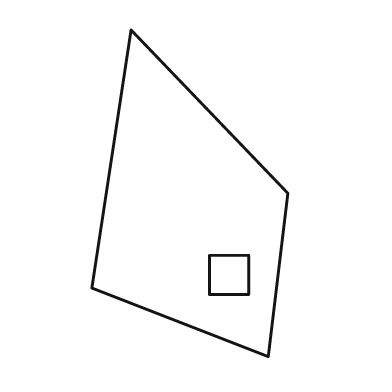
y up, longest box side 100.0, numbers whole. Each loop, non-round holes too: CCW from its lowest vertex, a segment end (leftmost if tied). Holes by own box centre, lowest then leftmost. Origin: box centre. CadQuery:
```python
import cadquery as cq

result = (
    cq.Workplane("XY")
    .moveTo(24.0, -50.0)
    .lineTo(30.0, 0.0)
    .lineTo(-18.0, 50.0)
    .lineTo(-30.0, -29.0)
    .close()
    .moveTo(6.0, -31.0)
    .lineTo(18.0, -31.0)
    .lineTo(18.0, -19.0)
    .lineTo(6.0, -19.0)
    .close()
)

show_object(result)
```